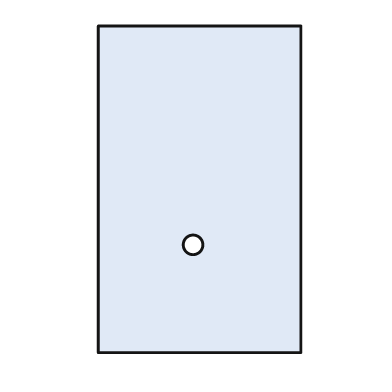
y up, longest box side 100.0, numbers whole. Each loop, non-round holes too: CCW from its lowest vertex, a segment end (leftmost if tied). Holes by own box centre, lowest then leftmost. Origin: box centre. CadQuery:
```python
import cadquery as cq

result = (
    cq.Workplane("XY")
    .moveTo(-31.0, -50.0)
    .lineTo(31.0, -50.0)
    .lineTo(31.0, 50.0)
    .lineTo(-31.0, 50.0)
    .close()
    .moveTo(-2.0, -17.0)
    .circle(3.0)
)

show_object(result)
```